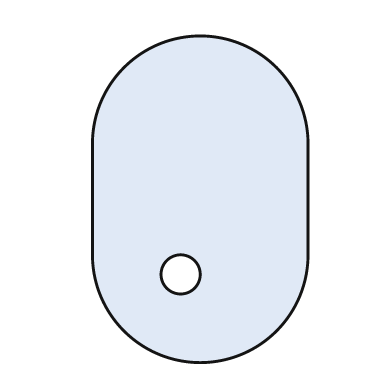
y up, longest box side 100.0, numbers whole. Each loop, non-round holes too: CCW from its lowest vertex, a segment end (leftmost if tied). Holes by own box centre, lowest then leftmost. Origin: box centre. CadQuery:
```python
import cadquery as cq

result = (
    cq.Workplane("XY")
    .moveTo(-33.0, -17.0)
    .threePointArc((0.0, -50.0), (33.0, -17.0))
    .lineTo(33.0, 17.0)
    .threePointArc((0.0, 50.0), (-33.0, 17.0))
    .close()
    .moveTo(-6.0, -23.0)
    .circle(6.0)
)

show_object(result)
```